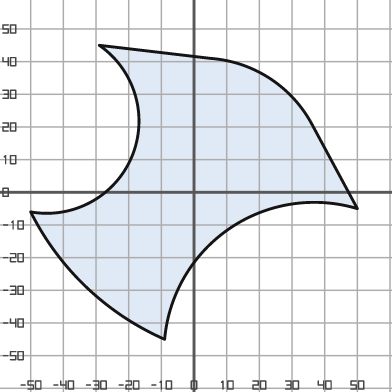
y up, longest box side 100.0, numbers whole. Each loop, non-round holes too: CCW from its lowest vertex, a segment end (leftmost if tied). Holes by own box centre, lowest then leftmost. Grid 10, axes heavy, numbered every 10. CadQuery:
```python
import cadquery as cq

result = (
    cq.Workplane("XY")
    .moveTo(-9.0, -45.0)
    .threePointArc((11.0, -11.0), (50.0, -5.0))
    .lineTo(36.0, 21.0)
    .threePointArc((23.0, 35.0), (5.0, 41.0))
    .lineTo(-29.0, 45.0)
    .threePointArc((-19.0, 11.0), (-50.0, -6.0))
    .threePointArc((-33.0, -29.0), (-9.0, -45.0))
    .close()
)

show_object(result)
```